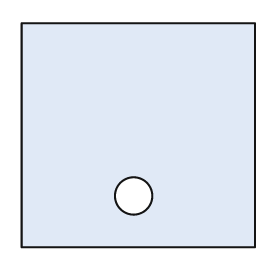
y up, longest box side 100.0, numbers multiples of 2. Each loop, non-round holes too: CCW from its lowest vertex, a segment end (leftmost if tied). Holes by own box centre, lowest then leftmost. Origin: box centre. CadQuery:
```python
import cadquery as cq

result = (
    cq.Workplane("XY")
    .moveTo(-50.0, -48.0)
    .lineTo(50.0, -48.0)
    .lineTo(50.0, 48.0)
    .lineTo(-50.0, 48.0)
    .close()
    .moveTo(-2.0, -26.0)
    .circle(8.0)
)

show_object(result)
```